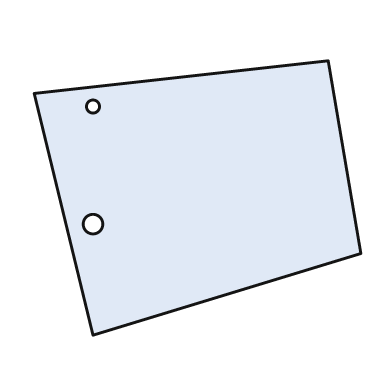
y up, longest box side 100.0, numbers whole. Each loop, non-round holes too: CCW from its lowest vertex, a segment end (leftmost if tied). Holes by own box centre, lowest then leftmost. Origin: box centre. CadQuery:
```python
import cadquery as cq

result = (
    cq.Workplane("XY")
    .moveTo(-32.0, -42.0)
    .lineTo(50.0, -17.0)
    .lineTo(40.0, 42.0)
    .lineTo(-50.0, 32.0)
    .close()
    .moveTo(-32.0, -8.0)
    .circle(3.0)
    .moveTo(-32.0, 28.0)
    .circle(2.0)
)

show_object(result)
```